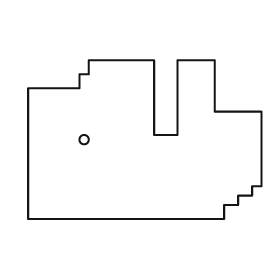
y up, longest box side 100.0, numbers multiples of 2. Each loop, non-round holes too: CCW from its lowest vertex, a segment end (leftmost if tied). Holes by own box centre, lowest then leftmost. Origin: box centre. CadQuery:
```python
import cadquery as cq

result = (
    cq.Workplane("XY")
    .moveTo(-50.0, -34.0)
    .lineTo(34.0, -34.0)
    .lineTo(34.0, -28.0)
    .lineTo(40.0, -28.0)
    .lineTo(40.0, -24.0)
    .lineTo(46.0, -24.0)
    .lineTo(46.0, -20.0)
    .lineTo(50.0, -20.0)
    .lineTo(50.0, 12.0)
    .lineTo(30.0, 12.0)
    .lineTo(30.0, 34.0)
    .lineTo(14.0, 34.0)
    .lineTo(14.0, 2.0)
    .lineTo(4.0, 2.0)
    .lineTo(4.0, 34.0)
    .lineTo(-24.0, 34.0)
    .lineTo(-24.0, 28.0)
    .lineTo(-28.0, 28.0)
    .lineTo(-28.0, 22.0)
    .lineTo(-50.0, 22.0)
    .close()
    .moveTo(-26.0, 0.0)
    .circle(2.0)
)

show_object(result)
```